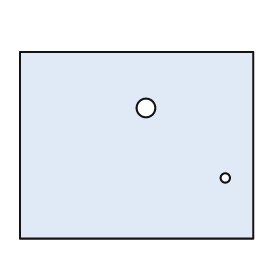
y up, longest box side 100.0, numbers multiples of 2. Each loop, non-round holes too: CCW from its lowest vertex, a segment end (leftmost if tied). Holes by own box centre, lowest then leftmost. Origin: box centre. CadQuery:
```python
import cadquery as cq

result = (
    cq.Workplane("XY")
    .moveTo(-50.0, -40.0)
    .lineTo(50.0, -40.0)
    .lineTo(50.0, 40.0)
    .lineTo(-50.0, 40.0)
    .close()
    .moveTo(38.0, -14.0)
    .circle(2.0)
    .moveTo(4.0, 16.0)
    .circle(4.0)
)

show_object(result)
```